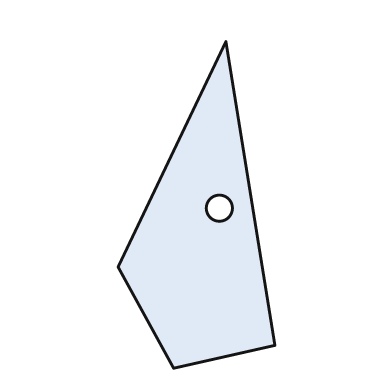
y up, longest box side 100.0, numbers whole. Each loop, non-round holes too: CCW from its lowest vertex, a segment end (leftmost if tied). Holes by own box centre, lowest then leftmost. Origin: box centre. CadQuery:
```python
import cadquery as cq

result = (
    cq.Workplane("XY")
    .moveTo(-7.0, -50.0)
    .lineTo(24.0, -43.0)
    .lineTo(9.0, 50.0)
    .lineTo(-24.0, -19.0)
    .close()
    .moveTo(7.0, -1.0)
    .circle(4.0)
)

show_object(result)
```